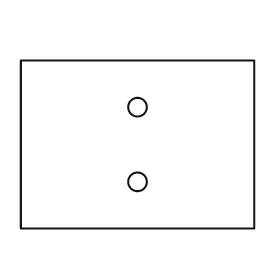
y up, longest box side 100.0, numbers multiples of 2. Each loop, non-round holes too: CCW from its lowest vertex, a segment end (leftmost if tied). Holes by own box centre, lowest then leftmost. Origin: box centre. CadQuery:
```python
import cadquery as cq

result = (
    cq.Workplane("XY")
    .moveTo(-50.0, -36.0)
    .lineTo(50.0, -36.0)
    .lineTo(50.0, 36.0)
    .lineTo(-50.0, 36.0)
    .close()
    .moveTo(0.0, -16.0)
    .circle(4.0)
    .moveTo(0.0, 16.0)
    .circle(4.0)
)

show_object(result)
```